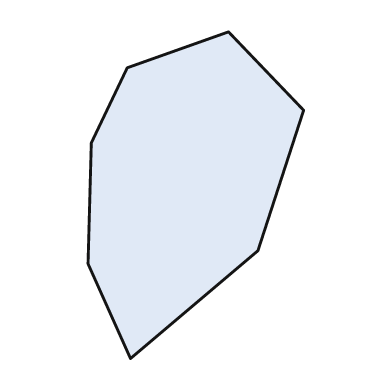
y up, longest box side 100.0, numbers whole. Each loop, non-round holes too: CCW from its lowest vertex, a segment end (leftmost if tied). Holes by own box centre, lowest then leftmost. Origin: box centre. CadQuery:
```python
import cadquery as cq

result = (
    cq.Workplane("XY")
    .moveTo(-20.0, -50.0)
    .lineTo(19.0, -17.0)
    .lineTo(33.0, 26.0)
    .lineTo(10.0, 50.0)
    .lineTo(-21.0, 39.0)
    .lineTo(-32.0, 16.0)
    .lineTo(-33.0, -21.0)
    .close()
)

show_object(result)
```